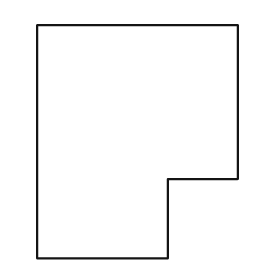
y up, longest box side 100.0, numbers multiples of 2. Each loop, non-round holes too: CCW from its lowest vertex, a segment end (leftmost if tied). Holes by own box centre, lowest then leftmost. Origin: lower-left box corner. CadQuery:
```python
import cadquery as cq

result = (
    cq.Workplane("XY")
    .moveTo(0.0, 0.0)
    .lineTo(56.0, 0.0)
    .lineTo(56.0, 34.0)
    .lineTo(86.0, 34.0)
    .lineTo(86.0, 100.0)
    .lineTo(0.0, 100.0)
    .close()
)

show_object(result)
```